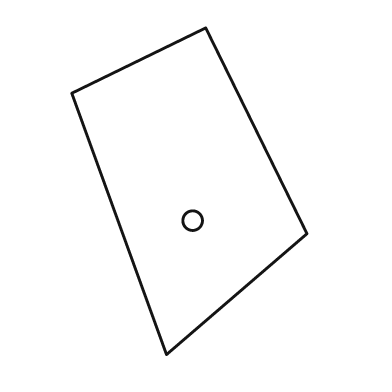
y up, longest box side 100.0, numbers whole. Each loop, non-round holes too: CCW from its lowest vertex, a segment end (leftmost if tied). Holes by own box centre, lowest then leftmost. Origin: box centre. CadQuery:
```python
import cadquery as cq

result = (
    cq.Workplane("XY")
    .moveTo(-7.0, -50.0)
    .lineTo(36.0, -13.0)
    .lineTo(5.0, 50.0)
    .lineTo(-36.0, 30.0)
    .close()
    .moveTo(1.0, -9.0)
    .circle(3.0)
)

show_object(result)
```